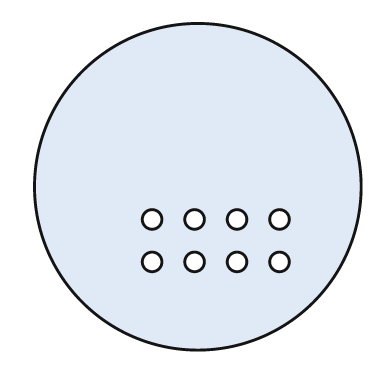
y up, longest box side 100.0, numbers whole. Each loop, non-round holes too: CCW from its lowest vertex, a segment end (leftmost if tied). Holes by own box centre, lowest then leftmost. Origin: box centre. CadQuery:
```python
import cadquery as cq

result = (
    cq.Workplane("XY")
    .moveTo(0.0, 0.0)
    .circle(50.0)
    .moveTo(-14.0, -23.0)
    .circle(3.0)
    .moveTo(-1.0, -23.0)
    .circle(3.0)
    .moveTo(12.0, -23.0)
    .circle(3.0)
    .moveTo(25.0, -23.0)
    .circle(3.0)
    .moveTo(-14.0, -10.0)
    .circle(3.0)
    .moveTo(-1.0, -10.0)
    .circle(3.0)
    .moveTo(12.0, -10.0)
    .circle(3.0)
    .moveTo(25.0, -10.0)
    .circle(3.0)
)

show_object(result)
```